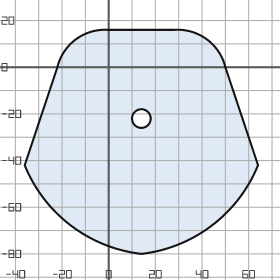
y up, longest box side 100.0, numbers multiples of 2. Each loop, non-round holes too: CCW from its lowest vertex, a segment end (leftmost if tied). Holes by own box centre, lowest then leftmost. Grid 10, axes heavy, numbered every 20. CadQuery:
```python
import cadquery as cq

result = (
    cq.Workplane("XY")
    .moveTo(14.0, -80.0)
    .threePointArc((44.0, -68.0), (64.0, -42.0))
    .lineTo(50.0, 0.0)
    .threePointArc((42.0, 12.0), (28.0, 16.0))
    .lineTo(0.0, 16.0)
    .threePointArc((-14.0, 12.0), (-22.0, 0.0))
    .lineTo(-36.0, -42.0)
    .threePointArc((-16.0, -68.0), (14.0, -80.0))
    .close()
    .moveTo(14.0, -22.0)
    .circle(4.0)
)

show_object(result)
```